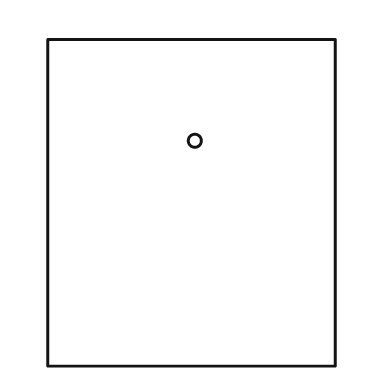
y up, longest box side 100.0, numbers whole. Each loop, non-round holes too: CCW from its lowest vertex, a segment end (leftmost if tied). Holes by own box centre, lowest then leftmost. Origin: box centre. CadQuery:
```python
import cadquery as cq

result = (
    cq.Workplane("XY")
    .moveTo(-44.0, -50.0)
    .lineTo(44.0, -50.0)
    .lineTo(44.0, 50.0)
    .lineTo(-44.0, 50.0)
    .close()
    .moveTo(1.0, 19.0)
    .circle(2.0)
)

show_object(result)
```